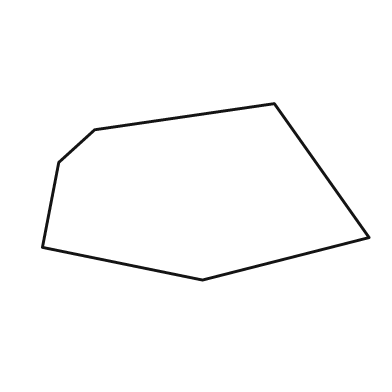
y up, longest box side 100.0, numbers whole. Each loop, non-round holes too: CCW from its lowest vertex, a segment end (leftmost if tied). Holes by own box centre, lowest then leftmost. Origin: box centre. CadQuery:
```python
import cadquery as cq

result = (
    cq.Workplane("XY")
    .moveTo(-1.0, -27.0)
    .lineTo(50.0, -14.0)
    .lineTo(21.0, 27.0)
    .lineTo(-34.0, 19.0)
    .lineTo(-45.0, 9.0)
    .lineTo(-50.0, -17.0)
    .close()
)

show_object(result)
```